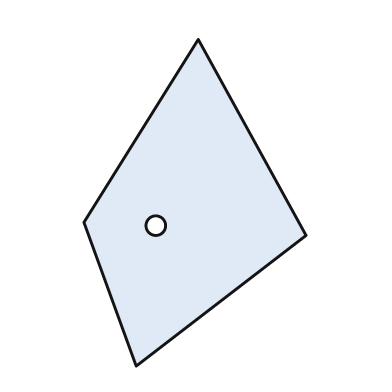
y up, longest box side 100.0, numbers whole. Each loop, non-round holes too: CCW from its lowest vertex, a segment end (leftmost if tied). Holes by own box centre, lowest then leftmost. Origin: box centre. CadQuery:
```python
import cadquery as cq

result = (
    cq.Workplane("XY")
    .moveTo(-18.0, -50.0)
    .lineTo(34.0, -10.0)
    .lineTo(1.0, 50.0)
    .lineTo(-34.0, -6.0)
    .close()
    .moveTo(-12.0, -7.0)
    .circle(3.0)
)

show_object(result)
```